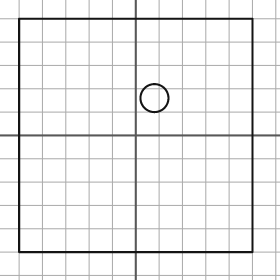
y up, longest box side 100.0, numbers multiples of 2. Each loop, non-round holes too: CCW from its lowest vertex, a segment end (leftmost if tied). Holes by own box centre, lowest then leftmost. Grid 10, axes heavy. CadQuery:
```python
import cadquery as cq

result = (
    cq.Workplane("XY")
    .moveTo(-50.0, -50.0)
    .lineTo(50.0, -50.0)
    .lineTo(50.0, 50.0)
    .lineTo(-50.0, 50.0)
    .close()
    .moveTo(8.0, 16.0)
    .circle(6.0)
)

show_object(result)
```